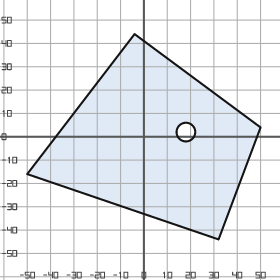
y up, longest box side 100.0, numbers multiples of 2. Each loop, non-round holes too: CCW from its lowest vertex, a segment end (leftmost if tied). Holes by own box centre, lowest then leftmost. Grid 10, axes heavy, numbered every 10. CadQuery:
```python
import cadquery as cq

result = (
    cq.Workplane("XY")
    .moveTo(32.0, -44.0)
    .lineTo(50.0, 4.0)
    .lineTo(-4.0, 44.0)
    .lineTo(-50.0, -16.0)
    .close()
    .moveTo(18.0, 2.0)
    .circle(4.0)
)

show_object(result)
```